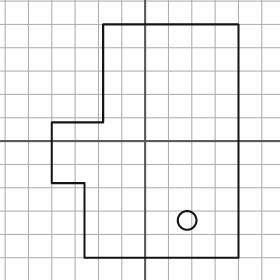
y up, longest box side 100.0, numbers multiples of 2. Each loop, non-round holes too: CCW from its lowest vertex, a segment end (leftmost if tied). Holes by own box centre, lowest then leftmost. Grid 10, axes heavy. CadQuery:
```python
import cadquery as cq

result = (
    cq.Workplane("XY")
    .moveTo(-26.0, -50.0)
    .lineTo(40.0, -50.0)
    .lineTo(40.0, 50.0)
    .lineTo(-18.0, 50.0)
    .lineTo(-18.0, 8.0)
    .lineTo(-40.0, 8.0)
    .lineTo(-40.0, -18.0)
    .lineTo(-26.0, -18.0)
    .close()
    .moveTo(18.0, -34.0)
    .circle(4.0)
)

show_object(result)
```